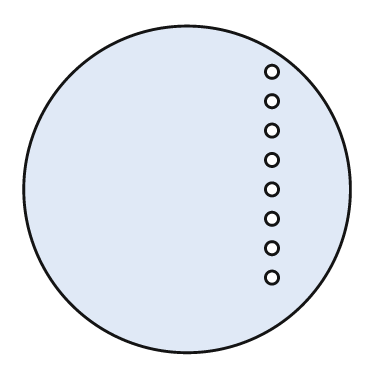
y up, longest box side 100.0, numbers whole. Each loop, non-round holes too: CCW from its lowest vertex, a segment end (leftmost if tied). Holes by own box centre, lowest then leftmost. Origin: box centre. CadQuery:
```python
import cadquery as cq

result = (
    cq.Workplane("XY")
    .moveTo(0.0, 0.0)
    .circle(50.0)
    .moveTo(26.0, -27.0)
    .circle(2.0)
    .moveTo(26.0, -18.0)
    .circle(2.0)
    .moveTo(26.0, -9.0)
    .circle(2.0)
    .moveTo(26.0, 0.0)
    .circle(2.0)
    .moveTo(26.0, 9.0)
    .circle(2.0)
    .moveTo(26.0, 18.0)
    .circle(2.0)
    .moveTo(26.0, 27.0)
    .circle(2.0)
    .moveTo(26.0, 36.0)
    .circle(2.0)
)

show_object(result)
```